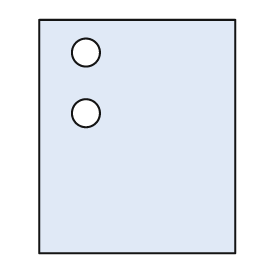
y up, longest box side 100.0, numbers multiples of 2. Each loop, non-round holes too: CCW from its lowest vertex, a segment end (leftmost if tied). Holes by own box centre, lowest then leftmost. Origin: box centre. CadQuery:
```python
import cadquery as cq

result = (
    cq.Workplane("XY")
    .moveTo(-42.0, -50.0)
    .lineTo(42.0, -50.0)
    .lineTo(42.0, 50.0)
    .lineTo(-42.0, 50.0)
    .close()
    .moveTo(-22.0, 10.0)
    .circle(6.0)
    .moveTo(-22.0, 36.0)
    .circle(6.0)
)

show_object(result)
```